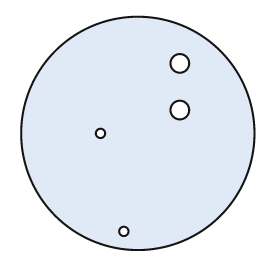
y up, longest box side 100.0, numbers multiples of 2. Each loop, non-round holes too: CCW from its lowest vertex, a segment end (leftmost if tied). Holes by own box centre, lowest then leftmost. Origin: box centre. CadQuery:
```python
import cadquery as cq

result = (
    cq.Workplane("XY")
    .moveTo(0.0, 0.0)
    .circle(50.0)
    .moveTo(-6.0, -42.0)
    .circle(2.0)
    .moveTo(-16.0, 0.0)
    .circle(2.0)
    .moveTo(18.0, 10.0)
    .circle(4.0)
    .moveTo(18.0, 30.0)
    .circle(4.0)
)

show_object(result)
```